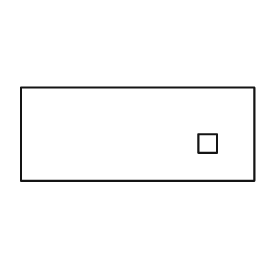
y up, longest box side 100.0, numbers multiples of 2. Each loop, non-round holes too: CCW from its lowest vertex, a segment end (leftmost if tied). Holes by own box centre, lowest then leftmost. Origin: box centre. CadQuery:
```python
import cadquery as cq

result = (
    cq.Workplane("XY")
    .moveTo(-50.0, -20.0)
    .lineTo(50.0, -20.0)
    .lineTo(50.0, 20.0)
    .lineTo(-50.0, 20.0)
    .close()
    .moveTo(26.0, -8.0)
    .lineTo(34.0, -8.0)
    .lineTo(34.0, 0.0)
    .lineTo(26.0, 0.0)
    .close()
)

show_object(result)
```